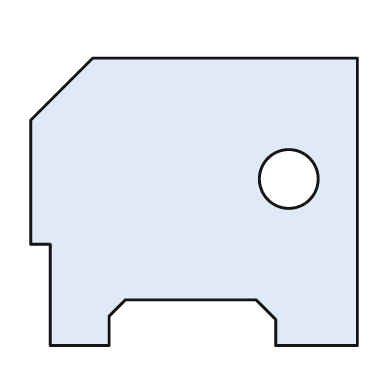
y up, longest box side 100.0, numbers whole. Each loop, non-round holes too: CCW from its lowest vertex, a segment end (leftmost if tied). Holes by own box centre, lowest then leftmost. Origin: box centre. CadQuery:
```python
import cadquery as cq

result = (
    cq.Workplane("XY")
    .moveTo(-44.0, -44.0)
    .lineTo(-26.0, -44.0)
    .lineTo(-26.0, -35.0)
    .lineTo(-21.0, -30.0)
    .lineTo(19.0, -30.0)
    .lineTo(25.0, -36.0)
    .lineTo(25.0, -44.0)
    .lineTo(50.0, -44.0)
    .lineTo(50.0, 44.0)
    .lineTo(-31.0, 44.0)
    .lineTo(-50.0, 25.0)
    .lineTo(-50.0, -13.0)
    .lineTo(-44.0, -13.0)
    .close()
    .moveTo(29.0, 7.0)
    .circle(9.0)
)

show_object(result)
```